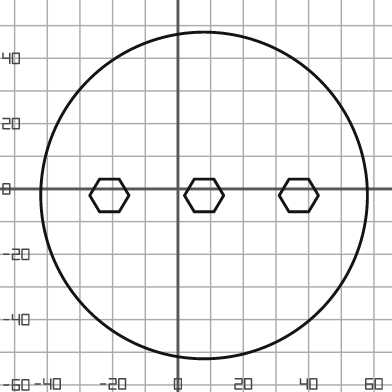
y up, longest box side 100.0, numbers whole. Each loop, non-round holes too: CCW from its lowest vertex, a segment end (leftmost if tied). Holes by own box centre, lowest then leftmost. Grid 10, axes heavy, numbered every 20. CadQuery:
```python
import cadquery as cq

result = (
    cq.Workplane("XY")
    .moveTo(8.0, -2.0)
    .circle(50.0)
    .moveTo(-24.0, -7.0)
    .lineTo(-18.0, -7.0)
    .lineTo(-15.0, -2.0)
    .lineTo(-18.0, 3.0)
    .lineTo(-24.0, 3.0)
    .lineTo(-27.0, -2.0)
    .close()
    .moveTo(5.0, -7.0)
    .lineTo(11.0, -7.0)
    .lineTo(14.0, -2.0)
    .lineTo(11.0, 3.0)
    .lineTo(5.0, 3.0)
    .lineTo(2.0, -2.0)
    .close()
    .moveTo(34.0, -7.0)
    .lineTo(40.0, -7.0)
    .lineTo(43.0, -2.0)
    .lineTo(40.0, 3.0)
    .lineTo(34.0, 3.0)
    .lineTo(31.0, -2.0)
    .close()
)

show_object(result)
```